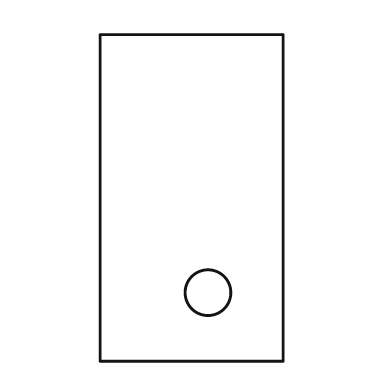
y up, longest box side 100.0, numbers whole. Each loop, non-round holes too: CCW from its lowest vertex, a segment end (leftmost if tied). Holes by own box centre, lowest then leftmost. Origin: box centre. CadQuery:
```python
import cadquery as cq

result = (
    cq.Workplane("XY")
    .moveTo(-28.0, -50.0)
    .lineTo(28.0, -50.0)
    .lineTo(28.0, 50.0)
    .lineTo(-28.0, 50.0)
    .close()
    .moveTo(5.0, -29.0)
    .circle(7.0)
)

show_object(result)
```